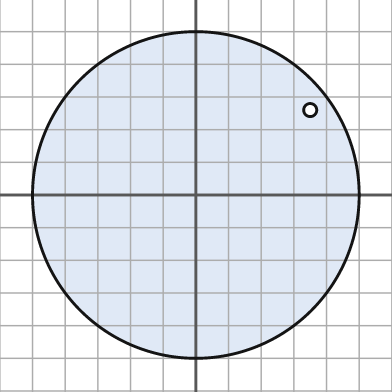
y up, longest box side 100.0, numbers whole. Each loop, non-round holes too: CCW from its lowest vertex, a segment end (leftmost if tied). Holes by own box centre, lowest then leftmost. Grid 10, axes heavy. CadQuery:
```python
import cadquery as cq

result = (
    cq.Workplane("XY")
    .moveTo(0.0, 0.0)
    .circle(50.0)
    .moveTo(35.0, 26.0)
    .circle(2.0)
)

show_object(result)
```